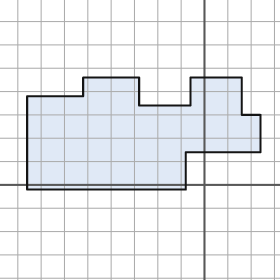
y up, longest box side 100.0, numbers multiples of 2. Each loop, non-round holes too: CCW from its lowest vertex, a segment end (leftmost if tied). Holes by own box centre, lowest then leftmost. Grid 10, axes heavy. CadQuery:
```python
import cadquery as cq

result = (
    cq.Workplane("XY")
    .moveTo(-76.0, -2.0)
    .lineTo(-8.0, -2.0)
    .lineTo(-8.0, 14.0)
    .lineTo(24.0, 14.0)
    .lineTo(24.0, 30.0)
    .lineTo(16.0, 30.0)
    .lineTo(16.0, 46.0)
    .lineTo(-6.0, 46.0)
    .lineTo(-6.0, 34.0)
    .lineTo(-28.0, 34.0)
    .lineTo(-28.0, 46.0)
    .lineTo(-52.0, 46.0)
    .lineTo(-52.0, 38.0)
    .lineTo(-76.0, 38.0)
    .close()
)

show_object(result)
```